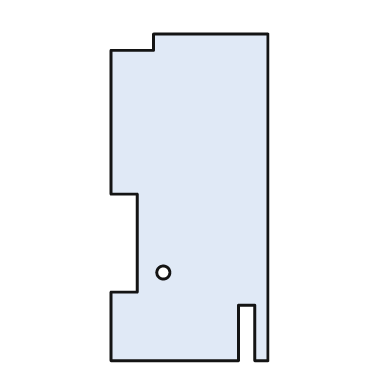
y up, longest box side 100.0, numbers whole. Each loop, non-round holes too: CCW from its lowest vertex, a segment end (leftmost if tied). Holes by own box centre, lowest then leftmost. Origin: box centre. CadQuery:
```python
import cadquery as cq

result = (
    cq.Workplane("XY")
    .moveTo(-24.0, -50.0)
    .lineTo(15.0, -50.0)
    .lineTo(15.0, -33.0)
    .lineTo(20.0, -33.0)
    .lineTo(20.0, -50.0)
    .lineTo(24.0, -50.0)
    .lineTo(24.0, 50.0)
    .lineTo(-11.0, 50.0)
    .lineTo(-11.0, 45.0)
    .lineTo(-24.0, 45.0)
    .lineTo(-24.0, 1.0)
    .lineTo(-16.0, 1.0)
    .lineTo(-16.0, -29.0)
    .lineTo(-24.0, -29.0)
    .close()
    .moveTo(-8.0, -23.0)
    .circle(2.0)
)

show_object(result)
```